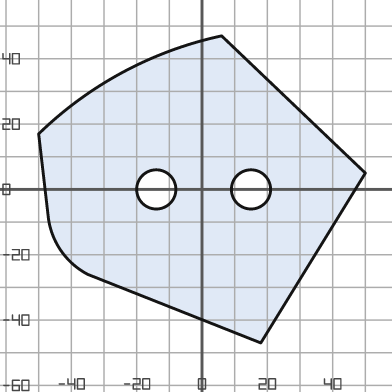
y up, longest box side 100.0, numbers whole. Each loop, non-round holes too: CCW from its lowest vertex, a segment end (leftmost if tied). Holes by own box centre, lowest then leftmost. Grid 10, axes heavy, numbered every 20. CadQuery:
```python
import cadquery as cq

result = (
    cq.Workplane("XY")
    .moveTo(18.0, -47.0)
    .lineTo(50.0, 5.0)
    .lineTo(6.0, 47.0)
    .threePointArc((-24.0, 36.0), (-50.0, 17.0))
    .lineTo(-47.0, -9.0)
    .threePointArc((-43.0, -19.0), (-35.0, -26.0))
    .close()
    .moveTo(-14.0, 0.0)
    .circle(6.0)
    .moveTo(15.0, 0.0)
    .circle(6.0)
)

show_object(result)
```